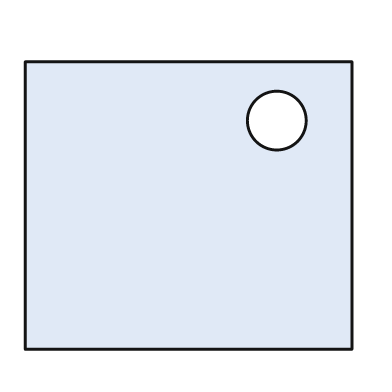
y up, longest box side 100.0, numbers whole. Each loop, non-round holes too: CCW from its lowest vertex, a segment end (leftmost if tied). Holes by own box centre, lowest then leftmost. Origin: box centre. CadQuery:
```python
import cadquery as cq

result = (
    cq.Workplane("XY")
    .moveTo(-50.0, -44.0)
    .lineTo(50.0, -44.0)
    .lineTo(50.0, 44.0)
    .lineTo(-50.0, 44.0)
    .close()
    .moveTo(27.0, 26.0)
    .circle(9.0)
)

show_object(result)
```